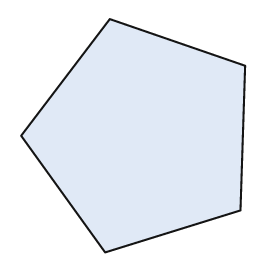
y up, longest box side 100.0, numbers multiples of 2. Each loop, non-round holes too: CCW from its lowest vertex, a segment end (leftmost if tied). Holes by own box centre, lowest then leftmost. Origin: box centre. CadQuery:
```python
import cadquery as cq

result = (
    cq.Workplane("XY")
    .moveTo(-12.0, -50.0)
    .lineTo(46.0, -32.0)
    .lineTo(48.0, 30.0)
    .lineTo(-10.0, 50.0)
    .lineTo(-48.0, 0.0)
    .close()
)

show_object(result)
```